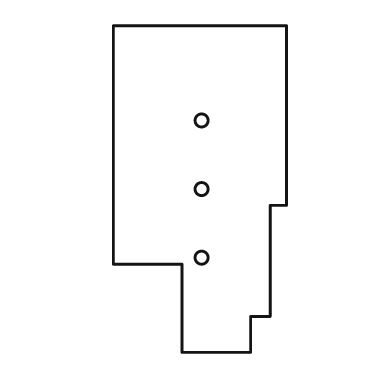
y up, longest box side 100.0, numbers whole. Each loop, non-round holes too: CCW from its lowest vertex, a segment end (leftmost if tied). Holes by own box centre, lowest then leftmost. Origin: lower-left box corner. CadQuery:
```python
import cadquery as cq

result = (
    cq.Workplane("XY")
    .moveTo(21.0, 0.0)
    .lineTo(42.0, 0.0)
    .lineTo(42.0, 11.0)
    .lineTo(48.0, 11.0)
    .lineTo(48.0, 45.0)
    .lineTo(53.0, 45.0)
    .lineTo(53.0, 100.0)
    .lineTo(0.0, 100.0)
    .lineTo(0.0, 27.0)
    .lineTo(21.0, 27.0)
    .close()
    .moveTo(27.0, 29.0)
    .circle(2.0)
    .moveTo(27.0, 50.0)
    .circle(2.0)
    .moveTo(27.0, 71.0)
    .circle(2.0)
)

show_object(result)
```